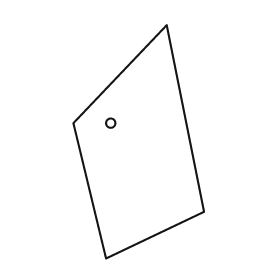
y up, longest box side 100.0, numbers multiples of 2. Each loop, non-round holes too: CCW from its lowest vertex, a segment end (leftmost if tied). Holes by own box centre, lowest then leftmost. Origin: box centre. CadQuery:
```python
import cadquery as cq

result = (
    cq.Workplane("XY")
    .moveTo(-14.0, -50.0)
    .lineTo(28.0, -30.0)
    .lineTo(12.0, 50.0)
    .lineTo(-28.0, 8.0)
    .close()
    .moveTo(-12.0, 8.0)
    .circle(2.0)
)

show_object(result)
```